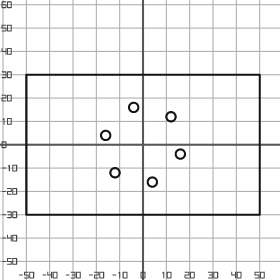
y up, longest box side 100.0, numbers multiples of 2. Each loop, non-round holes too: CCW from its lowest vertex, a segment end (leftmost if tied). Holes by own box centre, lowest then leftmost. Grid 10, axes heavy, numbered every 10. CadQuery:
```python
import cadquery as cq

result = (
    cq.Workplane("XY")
    .moveTo(-50.0, -30.0)
    .lineTo(50.0, -30.0)
    .lineTo(50.0, 30.0)
    .lineTo(-50.0, 30.0)
    .close()
    .moveTo(4.0, -16.0)
    .circle(2.0)
    .moveTo(-12.0, -12.0)
    .circle(2.0)
    .moveTo(16.0, -4.0)
    .circle(2.0)
    .moveTo(-16.0, 4.0)
    .circle(2.0)
    .moveTo(12.0, 12.0)
    .circle(2.0)
    .moveTo(-4.0, 16.0)
    .circle(2.0)
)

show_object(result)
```